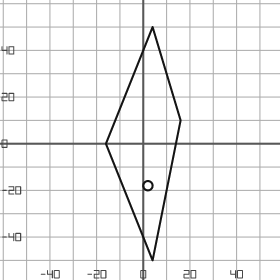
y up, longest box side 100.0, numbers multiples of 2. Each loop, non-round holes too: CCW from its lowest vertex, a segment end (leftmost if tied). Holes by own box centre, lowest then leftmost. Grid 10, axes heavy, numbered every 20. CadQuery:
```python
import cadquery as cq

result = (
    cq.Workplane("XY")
    .moveTo(4.0, -50.0)
    .lineTo(16.0, 10.0)
    .lineTo(4.0, 50.0)
    .lineTo(-16.0, 0.0)
    .close()
    .moveTo(2.0, -18.0)
    .circle(2.0)
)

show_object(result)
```